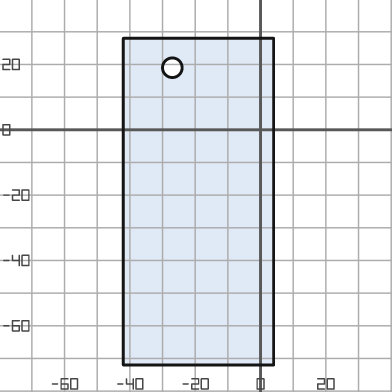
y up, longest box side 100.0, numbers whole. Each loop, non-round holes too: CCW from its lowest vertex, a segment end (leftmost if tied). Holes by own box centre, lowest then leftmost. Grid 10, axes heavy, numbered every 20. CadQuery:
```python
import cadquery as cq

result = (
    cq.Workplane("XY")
    .moveTo(-42.0, -72.0)
    .lineTo(4.0, -72.0)
    .lineTo(4.0, 28.0)
    .lineTo(-42.0, 28.0)
    .close()
    .moveTo(-27.0, 19.0)
    .circle(3.0)
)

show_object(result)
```